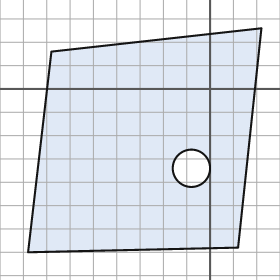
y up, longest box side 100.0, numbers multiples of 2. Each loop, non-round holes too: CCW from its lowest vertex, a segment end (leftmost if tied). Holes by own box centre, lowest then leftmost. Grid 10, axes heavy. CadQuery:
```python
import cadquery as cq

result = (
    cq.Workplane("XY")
    .moveTo(-78.0, -70.0)
    .lineTo(12.0, -68.0)
    .lineTo(22.0, 26.0)
    .lineTo(-68.0, 16.0)
    .close()
    .moveTo(-8.0, -34.0)
    .circle(8.0)
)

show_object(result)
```